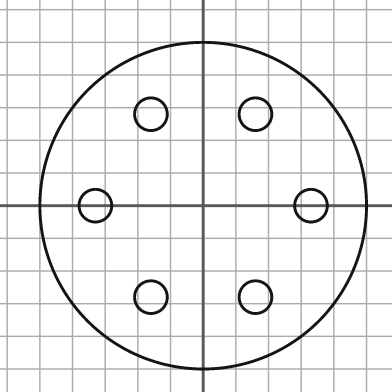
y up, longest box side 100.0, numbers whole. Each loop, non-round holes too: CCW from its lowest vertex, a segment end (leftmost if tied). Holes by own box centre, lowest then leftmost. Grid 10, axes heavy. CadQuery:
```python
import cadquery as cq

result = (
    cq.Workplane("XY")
    .moveTo(0.0, 0.0)
    .circle(50.0)
    .moveTo(-16.0, -28.0)
    .circle(5.0)
    .moveTo(16.0, -28.0)
    .circle(5.0)
    .moveTo(-33.0, 0.0)
    .circle(5.0)
    .moveTo(33.0, 0.0)
    .circle(5.0)
    .moveTo(-16.0, 28.0)
    .circle(5.0)
    .moveTo(16.0, 28.0)
    .circle(5.0)
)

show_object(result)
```